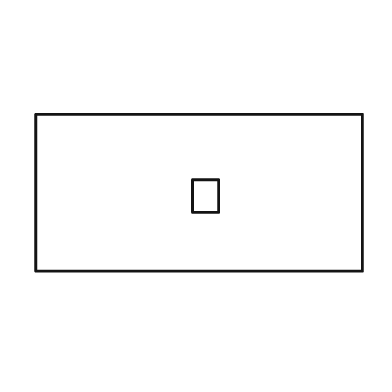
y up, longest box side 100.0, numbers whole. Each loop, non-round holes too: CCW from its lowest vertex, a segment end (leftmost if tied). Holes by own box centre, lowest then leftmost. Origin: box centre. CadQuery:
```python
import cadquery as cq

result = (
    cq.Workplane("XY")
    .moveTo(-50.0, -24.0)
    .lineTo(50.0, -24.0)
    .lineTo(50.0, 24.0)
    .lineTo(-50.0, 24.0)
    .close()
    .moveTo(-2.0, -6.0)
    .lineTo(6.0, -6.0)
    .lineTo(6.0, 4.0)
    .lineTo(-2.0, 4.0)
    .close()
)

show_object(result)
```